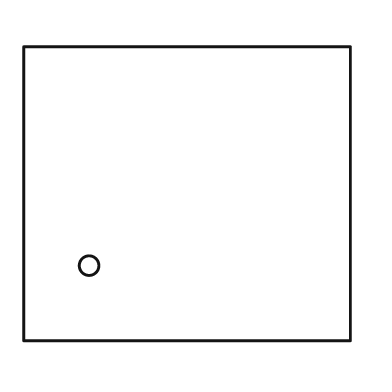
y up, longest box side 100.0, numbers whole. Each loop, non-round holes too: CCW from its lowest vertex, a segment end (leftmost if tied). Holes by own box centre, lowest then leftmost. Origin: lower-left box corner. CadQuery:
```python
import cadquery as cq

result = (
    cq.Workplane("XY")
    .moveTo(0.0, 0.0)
    .lineTo(100.0, 0.0)
    .lineTo(100.0, 90.0)
    .lineTo(0.0, 90.0)
    .close()
    .moveTo(20.0, 23.0)
    .circle(3.0)
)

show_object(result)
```